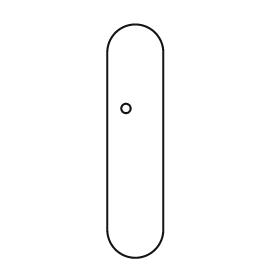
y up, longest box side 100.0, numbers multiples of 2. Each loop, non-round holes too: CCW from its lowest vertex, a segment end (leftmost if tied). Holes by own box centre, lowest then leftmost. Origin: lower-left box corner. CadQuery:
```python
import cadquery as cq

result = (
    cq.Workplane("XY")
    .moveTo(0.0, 12.0)
    .threePointArc((12.0, 0.0), (24.0, 12.0))
    .lineTo(24.0, 88.0)
    .threePointArc((12.0, 100.0), (0.0, 88.0))
    .close()
    .moveTo(8.0, 64.0)
    .circle(2.0)
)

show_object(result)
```